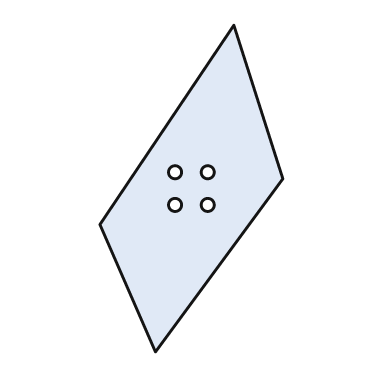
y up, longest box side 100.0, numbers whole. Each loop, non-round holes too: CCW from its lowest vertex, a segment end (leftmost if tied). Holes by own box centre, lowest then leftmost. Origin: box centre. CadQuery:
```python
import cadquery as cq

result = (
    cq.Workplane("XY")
    .moveTo(-11.0, -50.0)
    .lineTo(28.0, 3.0)
    .lineTo(13.0, 50.0)
    .lineTo(-28.0, -11.0)
    .close()
    .moveTo(-5.0, -5.0)
    .circle(2.0)
    .moveTo(5.0, -5.0)
    .circle(2.0)
    .moveTo(-5.0, 5.0)
    .circle(2.0)
    .moveTo(5.0, 5.0)
    .circle(2.0)
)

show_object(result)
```